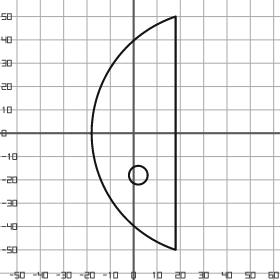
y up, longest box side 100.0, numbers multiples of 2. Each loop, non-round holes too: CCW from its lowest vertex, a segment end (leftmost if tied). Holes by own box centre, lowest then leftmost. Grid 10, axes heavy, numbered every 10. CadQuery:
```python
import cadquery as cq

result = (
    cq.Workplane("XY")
    .moveTo(18.0, -50.0)
    .lineTo(18.0, 50.0)
    .threePointArc((-18.0, 0.0), (18.0, -50.0))
    .close()
    .moveTo(2.0, -18.0)
    .circle(4.0)
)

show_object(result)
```